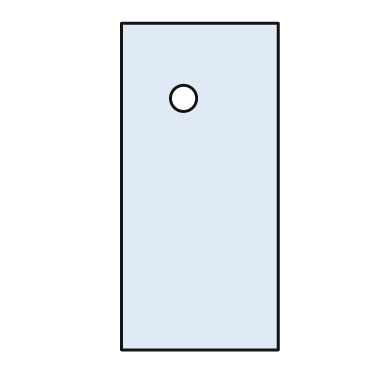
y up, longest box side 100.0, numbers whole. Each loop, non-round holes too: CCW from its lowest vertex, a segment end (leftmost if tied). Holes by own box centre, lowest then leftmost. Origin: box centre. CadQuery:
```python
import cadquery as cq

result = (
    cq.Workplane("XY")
    .moveTo(-24.0, -50.0)
    .lineTo(24.0, -50.0)
    .lineTo(24.0, 50.0)
    .lineTo(-24.0, 50.0)
    .close()
    .moveTo(-5.0, 27.0)
    .circle(4.0)
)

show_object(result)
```